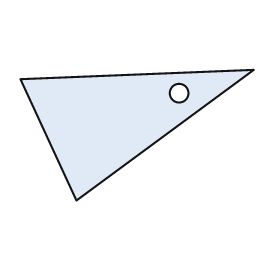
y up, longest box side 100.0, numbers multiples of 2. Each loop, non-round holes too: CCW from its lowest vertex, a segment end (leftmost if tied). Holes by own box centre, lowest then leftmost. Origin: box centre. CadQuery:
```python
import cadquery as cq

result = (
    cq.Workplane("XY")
    .moveTo(-26.0, -28.0)
    .lineTo(50.0, 28.0)
    .lineTo(-50.0, 24.0)
    .close()
    .moveTo(18.0, 18.0)
    .circle(4.0)
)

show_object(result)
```